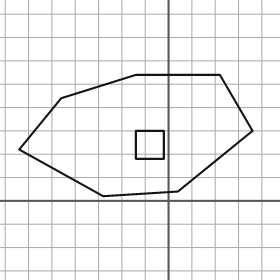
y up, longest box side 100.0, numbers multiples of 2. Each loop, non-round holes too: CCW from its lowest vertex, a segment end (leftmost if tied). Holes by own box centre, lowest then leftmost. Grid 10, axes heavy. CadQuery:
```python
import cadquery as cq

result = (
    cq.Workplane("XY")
    .moveTo(-28.0, 2.0)
    .lineTo(4.0, 4.0)
    .lineTo(36.0, 30.0)
    .lineTo(22.0, 54.0)
    .lineTo(-14.0, 54.0)
    .lineTo(-46.0, 44.0)
    .lineTo(-64.0, 22.0)
    .close()
    .moveTo(-14.0, 18.0)
    .lineTo(-2.0, 18.0)
    .lineTo(-2.0, 30.0)
    .lineTo(-14.0, 30.0)
    .close()
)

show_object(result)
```